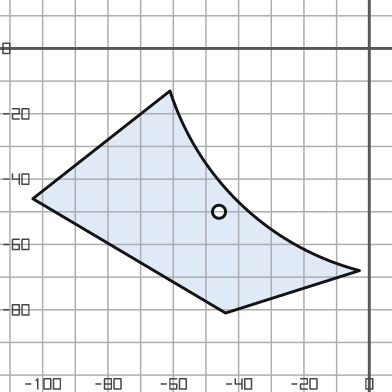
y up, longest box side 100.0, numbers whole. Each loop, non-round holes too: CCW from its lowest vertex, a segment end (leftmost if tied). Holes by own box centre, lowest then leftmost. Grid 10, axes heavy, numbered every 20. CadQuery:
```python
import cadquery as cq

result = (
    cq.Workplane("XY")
    .moveTo(-44.0, -81.0)
    .lineTo(-3.0, -68.0)
    .threePointArc((-39.0, -48.0), (-61.0, -13.0))
    .lineTo(-103.0, -46.0)
    .close()
    .moveTo(-46.0, -50.0)
    .circle(2.0)
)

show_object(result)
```